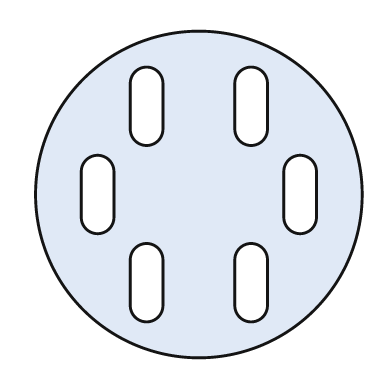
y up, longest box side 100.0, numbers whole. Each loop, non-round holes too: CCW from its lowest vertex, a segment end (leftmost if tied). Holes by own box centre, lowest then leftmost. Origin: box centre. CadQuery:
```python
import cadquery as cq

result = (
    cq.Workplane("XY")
    .moveTo(0.0, 0.0)
    .circle(50.0)
    .moveTo(-21.0, -34.0)
    .threePointArc((-16.0, -39.0), (-11.0, -34.0))
    .lineTo(-11.0, -20.0)
    .threePointArc((-16.0, -15.0), (-21.0, -20.0))
    .close()
    .moveTo(11.0, -34.0)
    .threePointArc((16.0, -39.0), (21.0, -34.0))
    .lineTo(21.0, -20.0)
    .threePointArc((16.0, -15.0), (11.0, -20.0))
    .close()
    .moveTo(-36.0, -7.0)
    .threePointArc((-31.0, -12.0), (-26.0, -7.0))
    .lineTo(-26.0, 7.0)
    .threePointArc((-31.0, 12.0), (-36.0, 7.0))
    .close()
    .moveTo(26.0, -7.0)
    .threePointArc((31.0, -12.0), (36.0, -7.0))
    .lineTo(36.0, 7.0)
    .threePointArc((31.0, 12.0), (26.0, 7.0))
    .close()
    .moveTo(-21.0, 20.0)
    .threePointArc((-16.0, 15.0), (-11.0, 20.0))
    .lineTo(-11.0, 34.0)
    .threePointArc((-16.0, 39.0), (-21.0, 34.0))
    .close()
    .moveTo(11.0, 20.0)
    .threePointArc((16.0, 15.0), (21.0, 20.0))
    .lineTo(21.0, 34.0)
    .threePointArc((16.0, 39.0), (11.0, 34.0))
    .close()
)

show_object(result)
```